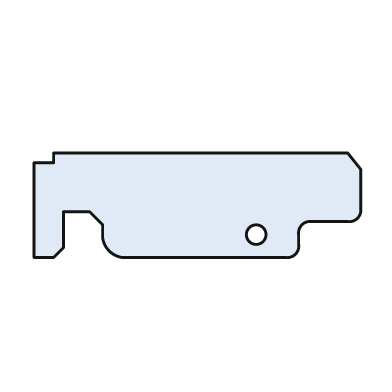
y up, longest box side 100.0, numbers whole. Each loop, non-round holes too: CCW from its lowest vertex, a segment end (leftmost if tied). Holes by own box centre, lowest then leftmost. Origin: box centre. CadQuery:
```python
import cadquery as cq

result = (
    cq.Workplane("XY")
    .moveTo(-50.0, -16.0)
    .lineTo(-44.0, -16.0)
    .lineTo(-41.0, -13.0)
    .lineTo(-41.0, -2.0)
    .lineTo(-33.0, -2.0)
    .lineTo(-29.0, -6.0)
    .lineTo(-29.0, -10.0)
    .threePointArc((-27.0, -14.0), (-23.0, -16.0))
    .lineTo(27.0, -16.0)
    .threePointArc((30.0, -15.0), (31.0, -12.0))
    .lineTo(31.0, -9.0)
    .threePointArc((32.0, -6.0), (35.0, -5.0))
    .lineTo(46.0, -5.0)
    .threePointArc((49.0, -4.0), (50.0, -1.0))
    .lineTo(50.0, 11.0)
    .lineTo(46.0, 16.0)
    .lineTo(-44.0, 16.0)
    .lineTo(-44.0, 13.0)
    .lineTo(-50.0, 13.0)
    .close()
    .moveTo(18.0, -9.0)
    .circle(3.0)
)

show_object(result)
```